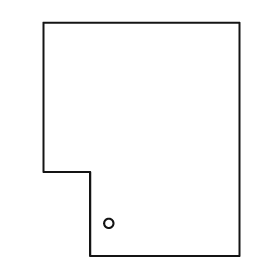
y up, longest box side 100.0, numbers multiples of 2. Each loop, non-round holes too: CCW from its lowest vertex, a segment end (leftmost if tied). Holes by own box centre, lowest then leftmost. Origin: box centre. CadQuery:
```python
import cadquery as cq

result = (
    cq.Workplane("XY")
    .moveTo(-22.0, -50.0)
    .lineTo(42.0, -50.0)
    .lineTo(42.0, 50.0)
    .lineTo(-42.0, 50.0)
    .lineTo(-42.0, -14.0)
    .lineTo(-22.0, -14.0)
    .close()
    .moveTo(-14.0, -36.0)
    .circle(2.0)
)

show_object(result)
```